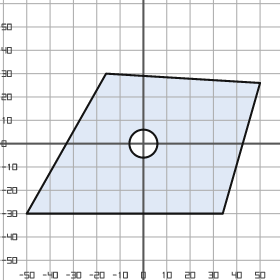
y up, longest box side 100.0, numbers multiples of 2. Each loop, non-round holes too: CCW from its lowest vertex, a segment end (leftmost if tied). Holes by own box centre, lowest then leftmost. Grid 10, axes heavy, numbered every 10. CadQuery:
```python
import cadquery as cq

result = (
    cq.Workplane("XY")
    .moveTo(-50.0, -30.0)
    .lineTo(34.0, -30.0)
    .lineTo(50.0, 26.0)
    .lineTo(-16.0, 30.0)
    .close()
    .moveTo(0.0, 0.0)
    .circle(6.0)
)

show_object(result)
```